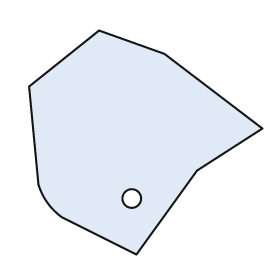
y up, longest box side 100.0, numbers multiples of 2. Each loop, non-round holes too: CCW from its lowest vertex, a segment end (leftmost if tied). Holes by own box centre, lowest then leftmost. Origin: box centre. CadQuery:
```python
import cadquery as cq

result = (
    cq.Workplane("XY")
    .moveTo(-4.0, -48.0)
    .lineTo(22.0, -12.0)
    .lineTo(50.0, 6.0)
    .lineTo(8.0, 38.0)
    .lineTo(-20.0, 48.0)
    .lineTo(-50.0, 24.0)
    .lineTo(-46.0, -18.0)
    .threePointArc((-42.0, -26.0), (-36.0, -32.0))
    .close()
    .moveTo(-6.0, -24.0)
    .circle(4.0)
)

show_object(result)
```